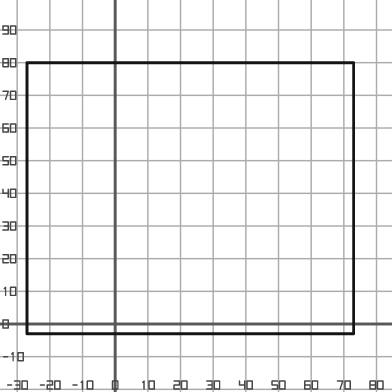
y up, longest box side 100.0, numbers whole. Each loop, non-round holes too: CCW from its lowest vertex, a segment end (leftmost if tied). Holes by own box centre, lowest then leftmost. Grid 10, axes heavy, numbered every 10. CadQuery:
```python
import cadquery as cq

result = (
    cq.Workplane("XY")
    .moveTo(-27.0, -3.0)
    .lineTo(73.0, -3.0)
    .lineTo(73.0, 80.0)
    .lineTo(-27.0, 80.0)
    .close()
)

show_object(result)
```